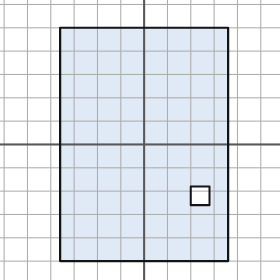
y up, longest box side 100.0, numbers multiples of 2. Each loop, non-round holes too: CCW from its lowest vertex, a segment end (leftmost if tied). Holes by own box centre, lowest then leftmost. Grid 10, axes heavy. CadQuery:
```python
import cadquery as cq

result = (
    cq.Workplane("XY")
    .moveTo(-36.0, -50.0)
    .lineTo(36.0, -50.0)
    .lineTo(36.0, 50.0)
    .lineTo(-36.0, 50.0)
    .close()
    .moveTo(20.0, -26.0)
    .lineTo(28.0, -26.0)
    .lineTo(28.0, -18.0)
    .lineTo(20.0, -18.0)
    .close()
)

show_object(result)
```